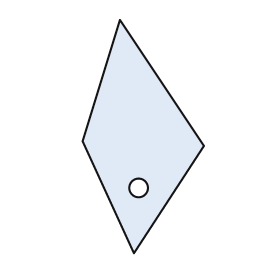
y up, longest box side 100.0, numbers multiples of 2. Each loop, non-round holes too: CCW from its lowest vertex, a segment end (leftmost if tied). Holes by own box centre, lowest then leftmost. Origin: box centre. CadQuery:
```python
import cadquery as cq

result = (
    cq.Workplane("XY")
    .moveTo(-4.0, -50.0)
    .lineTo(26.0, -4.0)
    .lineTo(-10.0, 50.0)
    .lineTo(-26.0, -2.0)
    .close()
    .moveTo(-2.0, -22.0)
    .circle(4.0)
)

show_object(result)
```